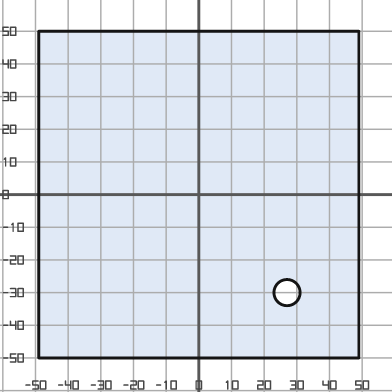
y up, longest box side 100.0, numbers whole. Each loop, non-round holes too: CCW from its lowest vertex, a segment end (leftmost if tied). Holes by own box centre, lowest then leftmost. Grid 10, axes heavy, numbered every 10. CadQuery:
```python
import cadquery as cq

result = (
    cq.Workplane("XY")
    .moveTo(-49.0, -50.0)
    .lineTo(49.0, -50.0)
    .lineTo(49.0, 50.0)
    .lineTo(-49.0, 50.0)
    .close()
    .moveTo(27.0, -30.0)
    .circle(4.0)
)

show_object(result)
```